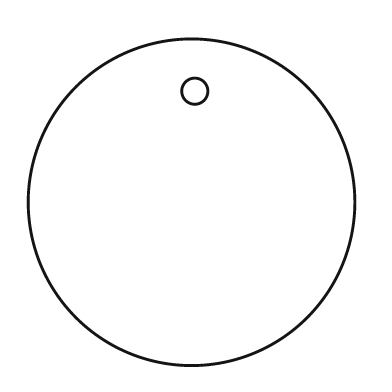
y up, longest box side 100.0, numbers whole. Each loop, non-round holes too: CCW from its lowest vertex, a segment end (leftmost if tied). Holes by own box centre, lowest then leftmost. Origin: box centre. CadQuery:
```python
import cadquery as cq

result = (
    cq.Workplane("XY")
    .moveTo(0.0, 0.0)
    .circle(50.0)
    .moveTo(1.0, 34.0)
    .circle(4.0)
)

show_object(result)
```